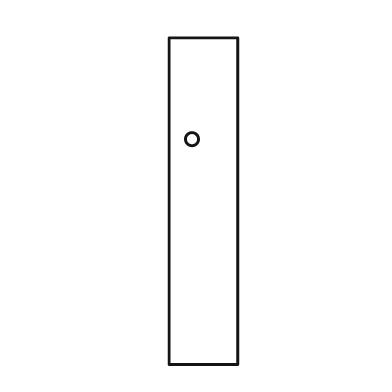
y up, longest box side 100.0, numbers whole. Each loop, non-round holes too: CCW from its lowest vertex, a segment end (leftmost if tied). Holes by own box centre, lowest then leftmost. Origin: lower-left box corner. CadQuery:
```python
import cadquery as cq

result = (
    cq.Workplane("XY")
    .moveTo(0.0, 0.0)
    .lineTo(21.0, 0.0)
    .lineTo(21.0, 100.0)
    .lineTo(0.0, 100.0)
    .close()
    .moveTo(7.0, 69.0)
    .circle(2.0)
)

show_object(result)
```